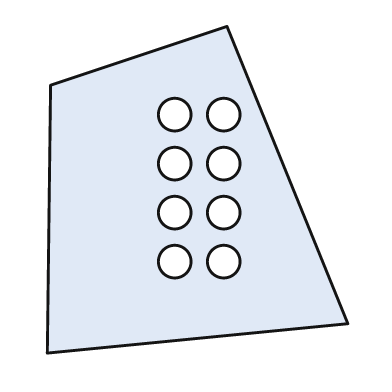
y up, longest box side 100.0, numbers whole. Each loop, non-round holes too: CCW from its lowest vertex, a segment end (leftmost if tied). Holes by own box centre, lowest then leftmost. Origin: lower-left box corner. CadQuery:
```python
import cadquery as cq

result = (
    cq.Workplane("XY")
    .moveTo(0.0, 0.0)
    .lineTo(92.0, 9.0)
    .lineTo(55.0, 100.0)
    .lineTo(1.0, 82.0)
    .close()
    .moveTo(39.0, 28.0)
    .circle(5.0)
    .moveTo(54.0, 28.0)
    .circle(5.0)
    .moveTo(39.0, 43.0)
    .circle(5.0)
    .moveTo(54.0, 43.0)
    .circle(5.0)
    .moveTo(39.0, 58.0)
    .circle(5.0)
    .moveTo(54.0, 58.0)
    .circle(5.0)
    .moveTo(39.0, 73.0)
    .circle(5.0)
    .moveTo(54.0, 73.0)
    .circle(5.0)
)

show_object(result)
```